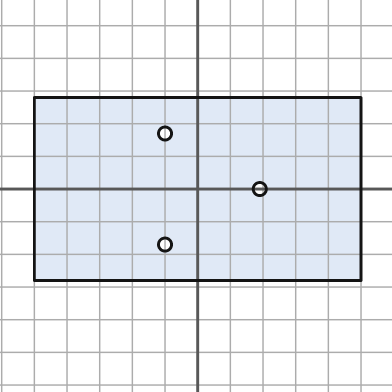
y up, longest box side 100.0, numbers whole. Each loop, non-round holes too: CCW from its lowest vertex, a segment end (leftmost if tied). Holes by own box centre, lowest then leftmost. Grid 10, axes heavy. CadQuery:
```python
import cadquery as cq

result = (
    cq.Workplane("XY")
    .moveTo(-50.0, -28.0)
    .lineTo(50.0, -28.0)
    .lineTo(50.0, 28.0)
    .lineTo(-50.0, 28.0)
    .close()
    .moveTo(-10.0, -17.0)
    .circle(2.0)
    .moveTo(19.0, 0.0)
    .circle(2.0)
    .moveTo(-10.0, 17.0)
    .circle(2.0)
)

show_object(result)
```